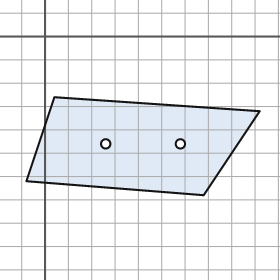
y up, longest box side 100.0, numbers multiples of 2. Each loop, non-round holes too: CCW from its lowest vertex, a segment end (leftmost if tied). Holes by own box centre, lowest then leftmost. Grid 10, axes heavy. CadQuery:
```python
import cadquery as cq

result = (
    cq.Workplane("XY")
    .moveTo(68.0, -68.0)
    .lineTo(92.0, -32.0)
    .lineTo(4.0, -26.0)
    .lineTo(-8.0, -62.0)
    .close()
    .moveTo(26.0, -46.0)
    .circle(2.0)
    .moveTo(58.0, -46.0)
    .circle(2.0)
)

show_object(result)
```